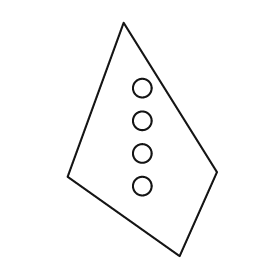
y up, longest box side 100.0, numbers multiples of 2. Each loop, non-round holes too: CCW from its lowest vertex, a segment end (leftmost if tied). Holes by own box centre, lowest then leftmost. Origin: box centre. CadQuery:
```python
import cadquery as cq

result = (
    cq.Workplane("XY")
    .moveTo(16.0, -50.0)
    .lineTo(32.0, -14.0)
    .lineTo(-8.0, 50.0)
    .lineTo(-32.0, -16.0)
    .close()
    .moveTo(0.0, -20.0)
    .circle(4.0)
    .moveTo(0.0, -6.0)
    .circle(4.0)
    .moveTo(0.0, 8.0)
    .circle(4.0)
    .moveTo(0.0, 22.0)
    .circle(4.0)
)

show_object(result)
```